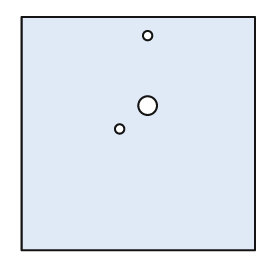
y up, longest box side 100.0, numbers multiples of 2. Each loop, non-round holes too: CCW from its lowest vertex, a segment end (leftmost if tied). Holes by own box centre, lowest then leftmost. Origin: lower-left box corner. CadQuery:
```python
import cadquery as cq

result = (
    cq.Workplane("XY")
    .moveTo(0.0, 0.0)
    .lineTo(100.0, 0.0)
    .lineTo(100.0, 100.0)
    .lineTo(0.0, 100.0)
    .close()
    .moveTo(42.0, 52.0)
    .circle(2.0)
    .moveTo(54.0, 62.0)
    .circle(4.0)
    .moveTo(54.0, 92.0)
    .circle(2.0)
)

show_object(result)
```